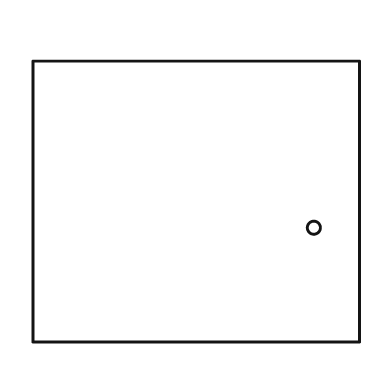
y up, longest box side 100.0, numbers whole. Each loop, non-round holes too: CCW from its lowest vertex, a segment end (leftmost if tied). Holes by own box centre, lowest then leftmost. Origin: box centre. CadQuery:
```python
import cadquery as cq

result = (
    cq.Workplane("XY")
    .moveTo(-50.0, -43.0)
    .lineTo(50.0, -43.0)
    .lineTo(50.0, 43.0)
    .lineTo(-50.0, 43.0)
    .close()
    .moveTo(36.0, -8.0)
    .circle(2.0)
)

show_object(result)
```